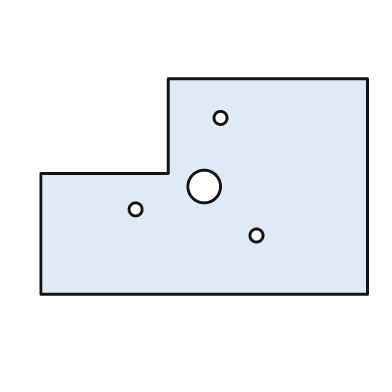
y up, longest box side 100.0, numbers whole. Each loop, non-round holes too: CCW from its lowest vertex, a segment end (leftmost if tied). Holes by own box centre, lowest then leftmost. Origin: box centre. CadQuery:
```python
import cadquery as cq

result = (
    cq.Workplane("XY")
    .moveTo(-50.0, -33.0)
    .lineTo(50.0, -33.0)
    .lineTo(50.0, 33.0)
    .lineTo(-11.0, 33.0)
    .lineTo(-11.0, 4.0)
    .lineTo(-50.0, 4.0)
    .close()
    .moveTo(16.0, -15.0)
    .circle(2.0)
    .moveTo(-21.0, -7.0)
    .circle(2.0)
    .moveTo(0.0, 0.0)
    .circle(5.0)
    .moveTo(5.0, 21.0)
    .circle(2.0)
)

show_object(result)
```